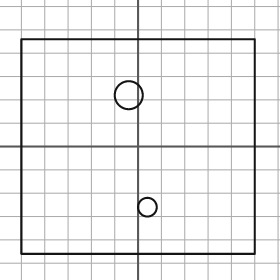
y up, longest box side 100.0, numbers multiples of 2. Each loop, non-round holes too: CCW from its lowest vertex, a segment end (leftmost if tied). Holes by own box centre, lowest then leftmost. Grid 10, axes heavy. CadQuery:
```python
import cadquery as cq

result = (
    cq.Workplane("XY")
    .moveTo(-50.0, -46.0)
    .lineTo(50.0, -46.0)
    .lineTo(50.0, 46.0)
    .lineTo(-50.0, 46.0)
    .close()
    .moveTo(4.0, -26.0)
    .circle(4.0)
    .moveTo(-4.0, 22.0)
    .circle(6.0)
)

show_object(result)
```